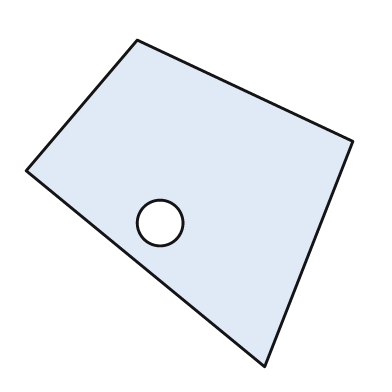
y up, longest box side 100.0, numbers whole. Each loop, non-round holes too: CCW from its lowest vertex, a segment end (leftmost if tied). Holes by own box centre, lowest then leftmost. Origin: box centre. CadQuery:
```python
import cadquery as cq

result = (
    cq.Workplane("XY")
    .moveTo(23.0, -50.0)
    .lineTo(50.0, 19.0)
    .lineTo(-16.0, 50.0)
    .lineTo(-50.0, 10.0)
    .close()
    .moveTo(-9.0, -6.0)
    .circle(7.0)
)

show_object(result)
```